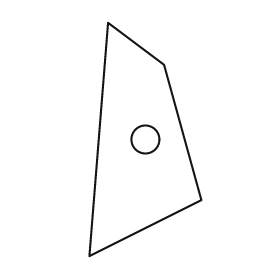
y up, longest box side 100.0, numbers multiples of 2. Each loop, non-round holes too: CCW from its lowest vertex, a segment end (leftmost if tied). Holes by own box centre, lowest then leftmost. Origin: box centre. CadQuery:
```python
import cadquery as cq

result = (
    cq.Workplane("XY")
    .moveTo(-24.0, -50.0)
    .lineTo(24.0, -26.0)
    .lineTo(8.0, 32.0)
    .lineTo(-16.0, 50.0)
    .close()
    .moveTo(0.0, 0.0)
    .circle(6.0)
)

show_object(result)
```